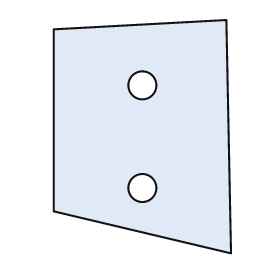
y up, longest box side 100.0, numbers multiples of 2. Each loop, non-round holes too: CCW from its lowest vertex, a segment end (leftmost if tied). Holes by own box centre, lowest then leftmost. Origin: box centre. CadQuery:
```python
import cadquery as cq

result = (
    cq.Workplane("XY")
    .moveTo(38.0, -50.0)
    .lineTo(36.0, 50.0)
    .lineTo(-38.0, 46.0)
    .lineTo(-38.0, -32.0)
    .close()
    .moveTo(0.0, -22.0)
    .circle(6.0)
    .moveTo(0.0, 22.0)
    .circle(6.0)
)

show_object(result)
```